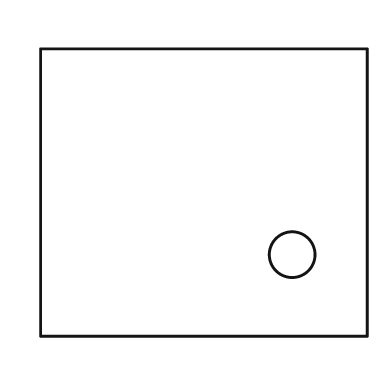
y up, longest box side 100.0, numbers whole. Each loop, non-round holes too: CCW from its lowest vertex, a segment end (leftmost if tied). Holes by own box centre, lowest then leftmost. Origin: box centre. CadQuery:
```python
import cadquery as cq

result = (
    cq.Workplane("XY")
    .moveTo(-50.0, -44.0)
    .lineTo(50.0, -44.0)
    .lineTo(50.0, 44.0)
    .lineTo(-50.0, 44.0)
    .close()
    .moveTo(27.0, -19.0)
    .circle(7.0)
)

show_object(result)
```